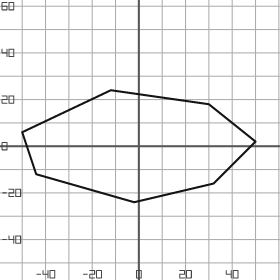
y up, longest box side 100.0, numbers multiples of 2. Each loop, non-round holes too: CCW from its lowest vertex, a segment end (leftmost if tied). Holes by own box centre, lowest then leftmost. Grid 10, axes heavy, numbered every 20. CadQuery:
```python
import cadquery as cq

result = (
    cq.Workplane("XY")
    .moveTo(-2.0, -24.0)
    .lineTo(32.0, -16.0)
    .lineTo(50.0, 2.0)
    .lineTo(30.0, 18.0)
    .lineTo(-12.0, 24.0)
    .lineTo(-50.0, 6.0)
    .lineTo(-44.0, -12.0)
    .close()
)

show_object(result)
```